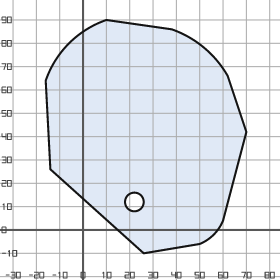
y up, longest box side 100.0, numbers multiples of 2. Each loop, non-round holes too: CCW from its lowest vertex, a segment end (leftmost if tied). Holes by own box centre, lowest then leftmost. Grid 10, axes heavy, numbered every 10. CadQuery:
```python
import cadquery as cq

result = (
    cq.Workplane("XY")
    .moveTo(26.0, -10.0)
    .lineTo(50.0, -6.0)
    .threePointArc((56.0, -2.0), (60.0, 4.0))
    .lineTo(70.0, 42.0)
    .lineTo(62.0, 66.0)
    .threePointArc((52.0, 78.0), (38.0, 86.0))
    .lineTo(10.0, 90.0)
    .threePointArc((-6.0, 80.0), (-16.0, 64.0))
    .lineTo(-14.0, 26.0)
    .close()
    .moveTo(22.0, 12.0)
    .circle(4.0)
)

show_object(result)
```